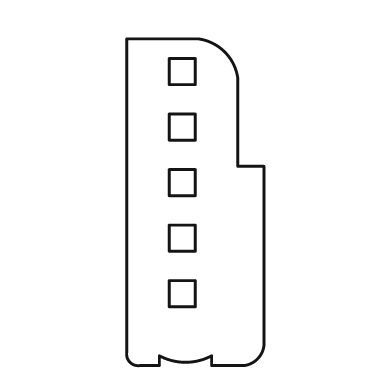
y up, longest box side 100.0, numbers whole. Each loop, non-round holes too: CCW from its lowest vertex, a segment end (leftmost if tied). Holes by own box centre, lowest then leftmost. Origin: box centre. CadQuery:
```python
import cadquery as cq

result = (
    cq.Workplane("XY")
    .moveTo(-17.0, -50.0)
    .lineTo(-11.0, -50.0)
    .lineTo(-11.0, -47.0)
    .threePointArc((-3.0, -49.0), (5.0, -47.0))
    .lineTo(5.0, -50.0)
    .lineTo(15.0, -50.0)
    .threePointArc((19.0, -48.0), (21.0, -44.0))
    .lineTo(21.0, 11.0)
    .lineTo(13.0, 11.0)
    .lineTo(13.0, 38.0)
    .threePointArc((9.0, 46.0), (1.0, 50.0))
    .lineTo(-21.0, 50.0)
    .lineTo(-21.0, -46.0)
    .threePointArc((-20.0, -49.0), (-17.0, -50.0))
    .close()
    .moveTo(-8.0, -32.0)
    .lineTo(0.0, -32.0)
    .lineTo(0.0, -24.0)
    .lineTo(-8.0, -24.0)
    .close()
    .moveTo(-8.0, -15.0)
    .lineTo(0.0, -15.0)
    .lineTo(0.0, -7.0)
    .lineTo(-8.0, -7.0)
    .close()
    .moveTo(-8.0, 2.0)
    .lineTo(0.0, 2.0)
    .lineTo(0.0, 10.0)
    .lineTo(-8.0, 10.0)
    .close()
    .moveTo(-8.0, 19.0)
    .lineTo(0.0, 19.0)
    .lineTo(0.0, 27.0)
    .lineTo(-8.0, 27.0)
    .close()
    .moveTo(-8.0, 36.0)
    .lineTo(0.0, 36.0)
    .lineTo(0.0, 44.0)
    .lineTo(-8.0, 44.0)
    .close()
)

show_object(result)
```